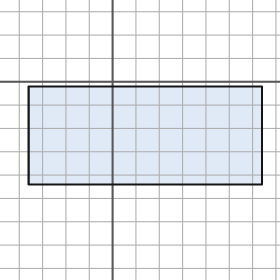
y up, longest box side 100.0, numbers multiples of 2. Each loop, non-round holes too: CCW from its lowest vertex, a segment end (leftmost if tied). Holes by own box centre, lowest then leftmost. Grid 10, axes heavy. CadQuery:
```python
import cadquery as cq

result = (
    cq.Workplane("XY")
    .moveTo(-36.0, -44.0)
    .lineTo(64.0, -44.0)
    .lineTo(64.0, -2.0)
    .lineTo(-36.0, -2.0)
    .close()
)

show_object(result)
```